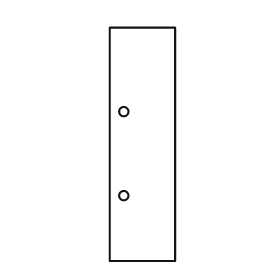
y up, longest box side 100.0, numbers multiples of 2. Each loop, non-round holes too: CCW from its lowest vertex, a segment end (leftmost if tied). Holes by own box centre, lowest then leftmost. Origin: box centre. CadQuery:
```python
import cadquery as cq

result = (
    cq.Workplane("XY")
    .moveTo(-14.0, -50.0)
    .lineTo(14.0, -50.0)
    .lineTo(14.0, 50.0)
    .lineTo(-14.0, 50.0)
    .close()
    .moveTo(-8.0, -22.0)
    .circle(2.0)
    .moveTo(-8.0, 14.0)
    .circle(2.0)
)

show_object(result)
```